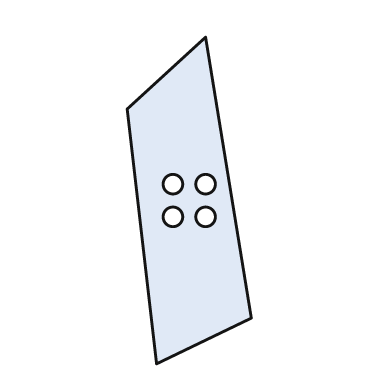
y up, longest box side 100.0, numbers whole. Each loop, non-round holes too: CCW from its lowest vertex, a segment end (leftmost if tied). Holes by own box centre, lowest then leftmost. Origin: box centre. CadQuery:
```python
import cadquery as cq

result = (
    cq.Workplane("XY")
    .moveTo(-10.0, -50.0)
    .lineTo(19.0, -36.0)
    .lineTo(5.0, 50.0)
    .lineTo(-19.0, 28.0)
    .close()
    .moveTo(-5.0, -5.0)
    .circle(3.0)
    .moveTo(5.0, -5.0)
    .circle(3.0)
    .moveTo(-5.0, 5.0)
    .circle(3.0)
    .moveTo(5.0, 5.0)
    .circle(3.0)
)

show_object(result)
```